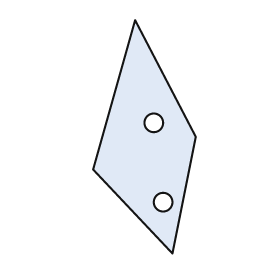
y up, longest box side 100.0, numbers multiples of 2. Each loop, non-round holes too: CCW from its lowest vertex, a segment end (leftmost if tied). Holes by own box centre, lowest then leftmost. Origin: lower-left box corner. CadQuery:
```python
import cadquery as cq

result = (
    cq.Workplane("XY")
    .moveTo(34.0, 0.0)
    .lineTo(44.0, 50.0)
    .lineTo(18.0, 100.0)
    .lineTo(0.0, 36.0)
    .close()
    .moveTo(30.0, 22.0)
    .circle(4.0)
    .moveTo(26.0, 56.0)
    .circle(4.0)
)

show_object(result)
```